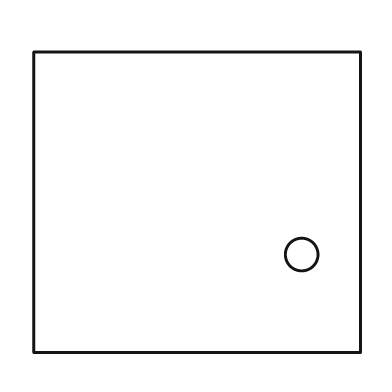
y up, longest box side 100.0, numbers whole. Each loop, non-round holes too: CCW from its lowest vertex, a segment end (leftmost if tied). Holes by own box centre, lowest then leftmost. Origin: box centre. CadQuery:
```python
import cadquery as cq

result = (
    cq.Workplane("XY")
    .moveTo(-50.0, -46.0)
    .lineTo(50.0, -46.0)
    .lineTo(50.0, 46.0)
    .lineTo(-50.0, 46.0)
    .close()
    .moveTo(32.0, -16.0)
    .circle(5.0)
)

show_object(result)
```